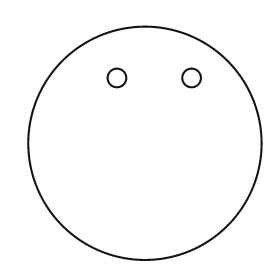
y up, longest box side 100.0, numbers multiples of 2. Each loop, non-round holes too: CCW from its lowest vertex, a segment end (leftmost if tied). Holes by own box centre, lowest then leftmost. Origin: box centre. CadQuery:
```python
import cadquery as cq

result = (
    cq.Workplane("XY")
    .moveTo(0.0, 0.0)
    .circle(50.0)
    .moveTo(-12.0, 28.0)
    .circle(4.0)
    .moveTo(20.0, 28.0)
    .circle(4.0)
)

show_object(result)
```